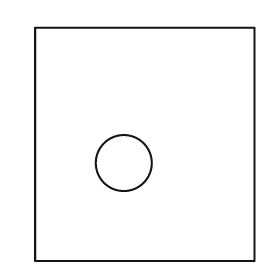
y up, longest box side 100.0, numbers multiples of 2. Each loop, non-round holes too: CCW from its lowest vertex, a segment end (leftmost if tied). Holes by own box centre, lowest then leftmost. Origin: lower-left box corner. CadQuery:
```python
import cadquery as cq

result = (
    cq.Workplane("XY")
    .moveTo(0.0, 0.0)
    .lineTo(94.0, 0.0)
    .lineTo(94.0, 100.0)
    .lineTo(0.0, 100.0)
    .close()
    .moveTo(38.0, 42.0)
    .circle(12.0)
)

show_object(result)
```